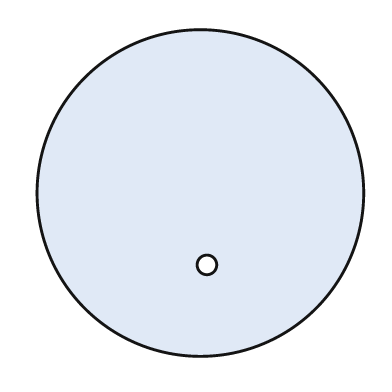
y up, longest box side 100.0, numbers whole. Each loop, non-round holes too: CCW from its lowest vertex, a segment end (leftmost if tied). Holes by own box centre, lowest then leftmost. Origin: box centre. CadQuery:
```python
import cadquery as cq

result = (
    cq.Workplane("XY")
    .moveTo(0.0, 0.0)
    .circle(50.0)
    .moveTo(2.0, -22.0)
    .circle(3.0)
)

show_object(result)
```